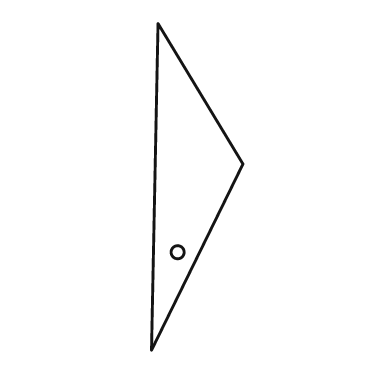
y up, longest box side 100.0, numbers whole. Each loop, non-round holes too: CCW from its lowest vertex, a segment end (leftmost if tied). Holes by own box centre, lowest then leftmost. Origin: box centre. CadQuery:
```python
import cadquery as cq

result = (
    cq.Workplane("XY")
    .moveTo(-14.0, -50.0)
    .lineTo(14.0, 7.0)
    .lineTo(-12.0, 50.0)
    .close()
    .moveTo(-6.0, -20.0)
    .circle(2.0)
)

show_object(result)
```